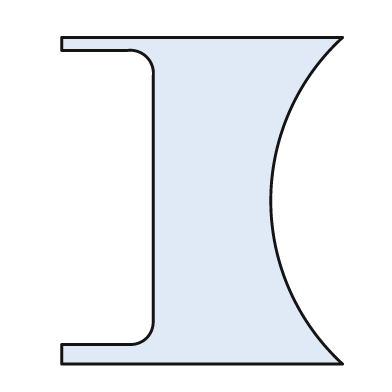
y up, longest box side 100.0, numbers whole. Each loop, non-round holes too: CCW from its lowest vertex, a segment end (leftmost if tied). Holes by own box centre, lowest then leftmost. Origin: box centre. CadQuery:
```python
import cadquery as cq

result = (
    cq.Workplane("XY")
    .moveTo(-43.0, -50.0)
    .lineTo(43.0, -50.0)
    .threePointArc((21.0, 0.0), (43.0, 50.0))
    .lineTo(-43.0, 50.0)
    .lineTo(-43.0, 46.0)
    .lineTo(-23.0, 46.0)
    .threePointArc((-17.0, 44.0), (-15.0, 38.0))
    .lineTo(-15.0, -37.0)
    .threePointArc((-17.0, -42.0), (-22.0, -44.0))
    .lineTo(-43.0, -44.0)
    .close()
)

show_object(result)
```